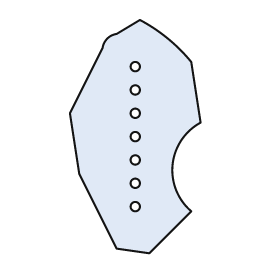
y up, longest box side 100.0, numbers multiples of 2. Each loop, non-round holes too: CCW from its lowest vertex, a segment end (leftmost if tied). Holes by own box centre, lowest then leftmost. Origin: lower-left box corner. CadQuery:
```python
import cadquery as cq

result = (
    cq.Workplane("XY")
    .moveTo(34.0, 0.0)
    .lineTo(52.0, 18.0)
    .threePointArc((44.0, 38.0), (56.0, 56.0))
    .lineTo(52.0, 82.0)
    .threePointArc((42.0, 92.0), (30.0, 100.0))
    .lineTo(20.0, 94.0)
    .threePointArc((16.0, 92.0), (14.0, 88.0))
    .lineTo(0.0, 60.0)
    .lineTo(4.0, 34.0)
    .lineTo(20.0, 2.0)
    .close()
    .moveTo(28.0, 20.0)
    .circle(2.0)
    .moveTo(28.0, 30.0)
    .circle(2.0)
    .moveTo(28.0, 40.0)
    .circle(2.0)
    .moveTo(28.0, 50.0)
    .circle(2.0)
    .moveTo(28.0, 60.0)
    .circle(2.0)
    .moveTo(28.0, 70.0)
    .circle(2.0)
    .moveTo(28.0, 80.0)
    .circle(2.0)
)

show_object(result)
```